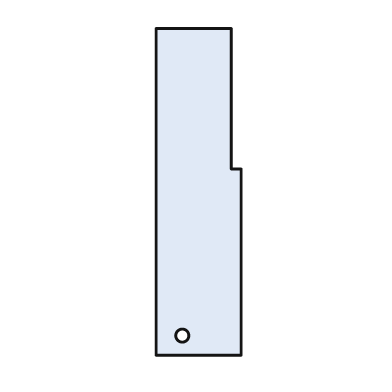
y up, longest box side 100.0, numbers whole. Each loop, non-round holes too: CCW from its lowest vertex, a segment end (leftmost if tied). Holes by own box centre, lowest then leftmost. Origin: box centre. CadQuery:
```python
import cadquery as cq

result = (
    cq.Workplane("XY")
    .moveTo(-13.0, -50.0)
    .lineTo(13.0, -50.0)
    .lineTo(13.0, 7.0)
    .lineTo(10.0, 7.0)
    .lineTo(10.0, 50.0)
    .lineTo(-13.0, 50.0)
    .close()
    .moveTo(-5.0, -44.0)
    .circle(2.0)
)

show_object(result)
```